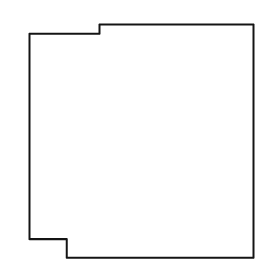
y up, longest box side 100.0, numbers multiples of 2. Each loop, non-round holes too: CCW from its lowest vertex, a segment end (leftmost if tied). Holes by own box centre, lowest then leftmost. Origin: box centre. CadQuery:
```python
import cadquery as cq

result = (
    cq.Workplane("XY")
    .moveTo(-32.0, -50.0)
    .lineTo(48.0, -50.0)
    .lineTo(48.0, 50.0)
    .lineTo(-18.0, 50.0)
    .lineTo(-18.0, 46.0)
    .lineTo(-48.0, 46.0)
    .lineTo(-48.0, -42.0)
    .lineTo(-32.0, -42.0)
    .close()
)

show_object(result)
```